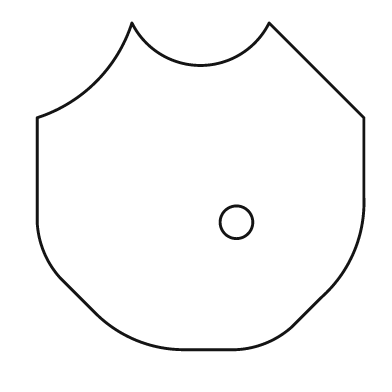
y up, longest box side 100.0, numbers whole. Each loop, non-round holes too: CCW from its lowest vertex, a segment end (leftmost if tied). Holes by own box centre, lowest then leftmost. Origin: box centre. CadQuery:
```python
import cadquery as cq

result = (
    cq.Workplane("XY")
    .moveTo(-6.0, -50.0)
    .lineTo(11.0, -50.0)
    .threePointArc((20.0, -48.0), (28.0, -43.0))
    .lineTo(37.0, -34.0)
    .threePointArc((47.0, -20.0), (50.0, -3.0))
    .lineTo(50.0, 21.0)
    .lineTo(21.0, 50.0)
    .threePointArc((0.0, 37.0), (-21.0, 50.0))
    .threePointArc((-32.0, 32.0), (-50.0, 21.0))
    .lineTo(-50.0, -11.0)
    .threePointArc((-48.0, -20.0), (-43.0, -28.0))
    .lineTo(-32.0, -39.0)
    .threePointArc((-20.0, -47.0), (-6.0, -50.0))
    .close()
    .moveTo(11.0, -11.0)
    .circle(5.0)
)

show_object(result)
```